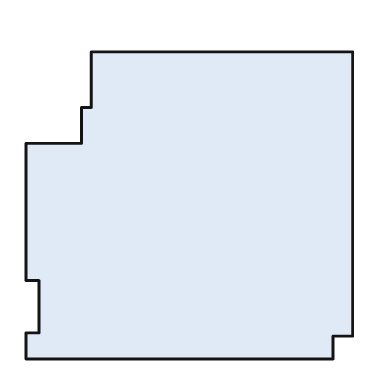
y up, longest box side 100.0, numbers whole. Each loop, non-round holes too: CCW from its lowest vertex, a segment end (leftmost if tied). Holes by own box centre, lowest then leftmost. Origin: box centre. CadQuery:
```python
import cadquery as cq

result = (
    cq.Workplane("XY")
    .moveTo(-50.0, -47.0)
    .lineTo(44.0, -47.0)
    .lineTo(44.0, -40.0)
    .lineTo(50.0, -40.0)
    .lineTo(50.0, 47.0)
    .lineTo(-30.0, 47.0)
    .lineTo(-30.0, 30.0)
    .lineTo(-33.0, 30.0)
    .lineTo(-33.0, 19.0)
    .lineTo(-50.0, 19.0)
    .lineTo(-50.0, -23.0)
    .lineTo(-46.0, -23.0)
    .lineTo(-46.0, -39.0)
    .lineTo(-50.0, -39.0)
    .close()
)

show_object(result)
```